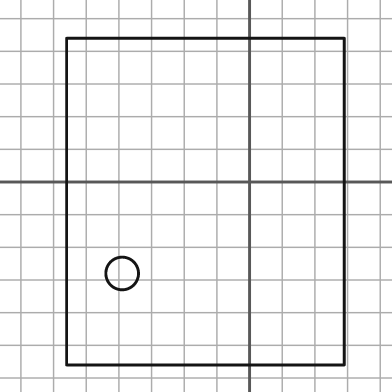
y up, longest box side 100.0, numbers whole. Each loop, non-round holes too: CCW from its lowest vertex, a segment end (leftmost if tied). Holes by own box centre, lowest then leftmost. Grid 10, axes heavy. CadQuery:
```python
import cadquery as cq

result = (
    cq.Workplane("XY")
    .moveTo(-56.0, -56.0)
    .lineTo(29.0, -56.0)
    .lineTo(29.0, 44.0)
    .lineTo(-56.0, 44.0)
    .close()
    .moveTo(-39.0, -28.0)
    .circle(5.0)
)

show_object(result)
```